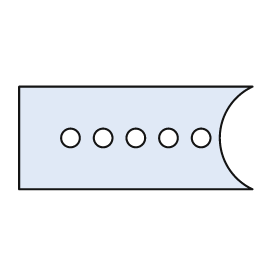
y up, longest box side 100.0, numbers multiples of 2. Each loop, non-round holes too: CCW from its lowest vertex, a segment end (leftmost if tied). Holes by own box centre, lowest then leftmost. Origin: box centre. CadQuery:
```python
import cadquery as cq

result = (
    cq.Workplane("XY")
    .moveTo(-50.0, -22.0)
    .lineTo(50.0, -22.0)
    .threePointArc((36.0, 0.0), (50.0, 22.0))
    .lineTo(-50.0, 22.0)
    .close()
    .moveTo(-28.0, 0.0)
    .circle(4.0)
    .moveTo(-14.0, 0.0)
    .circle(4.0)
    .moveTo(0.0, 0.0)
    .circle(4.0)
    .moveTo(14.0, 0.0)
    .circle(4.0)
    .moveTo(28.0, 0.0)
    .circle(4.0)
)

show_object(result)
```